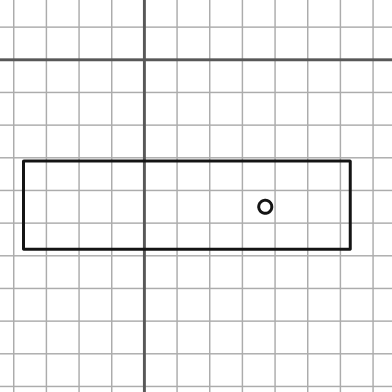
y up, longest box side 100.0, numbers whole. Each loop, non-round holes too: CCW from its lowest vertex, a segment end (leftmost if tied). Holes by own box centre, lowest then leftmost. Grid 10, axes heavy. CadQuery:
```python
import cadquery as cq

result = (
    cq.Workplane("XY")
    .moveTo(-37.0, -58.0)
    .lineTo(63.0, -58.0)
    .lineTo(63.0, -31.0)
    .lineTo(-37.0, -31.0)
    .close()
    .moveTo(37.0, -45.0)
    .circle(2.0)
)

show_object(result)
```